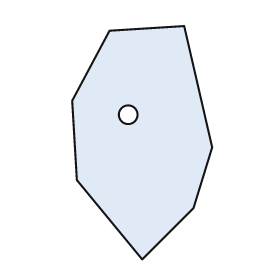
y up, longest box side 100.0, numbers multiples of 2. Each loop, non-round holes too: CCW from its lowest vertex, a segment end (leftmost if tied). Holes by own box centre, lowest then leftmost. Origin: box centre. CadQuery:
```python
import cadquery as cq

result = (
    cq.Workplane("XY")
    .moveTo(0.0, -50.0)
    .lineTo(22.0, -28.0)
    .lineTo(30.0, -2.0)
    .lineTo(18.0, 50.0)
    .lineTo(-14.0, 48.0)
    .lineTo(-30.0, 18.0)
    .lineTo(-28.0, -16.0)
    .close()
    .moveTo(-6.0, 12.0)
    .circle(4.0)
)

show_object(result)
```